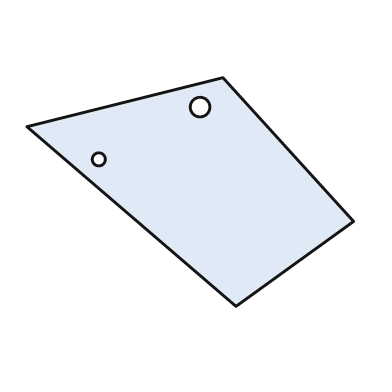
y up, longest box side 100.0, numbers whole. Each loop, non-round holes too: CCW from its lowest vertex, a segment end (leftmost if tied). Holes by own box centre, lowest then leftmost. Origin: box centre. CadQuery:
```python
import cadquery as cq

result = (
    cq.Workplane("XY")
    .moveTo(14.0, -35.0)
    .lineTo(50.0, -9.0)
    .lineTo(10.0, 35.0)
    .lineTo(-50.0, 20.0)
    .close()
    .moveTo(-28.0, 10.0)
    .circle(2.0)
    .moveTo(3.0, 26.0)
    .circle(3.0)
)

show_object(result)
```